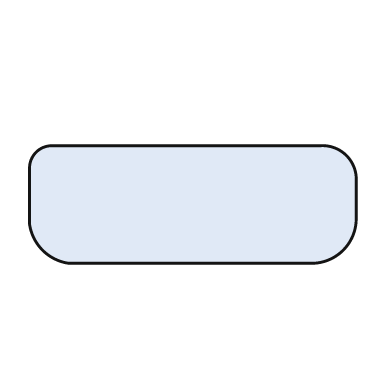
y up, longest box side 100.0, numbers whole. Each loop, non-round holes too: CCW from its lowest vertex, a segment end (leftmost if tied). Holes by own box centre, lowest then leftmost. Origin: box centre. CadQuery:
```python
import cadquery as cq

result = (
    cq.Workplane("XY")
    .moveTo(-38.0, -18.0)
    .lineTo(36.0, -18.0)
    .threePointArc((46.0, -14.0), (50.0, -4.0))
    .lineTo(50.0, 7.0)
    .threePointArc((47.0, 15.0), (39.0, 18.0))
    .lineTo(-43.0, 18.0)
    .threePointArc((-48.0, 16.0), (-50.0, 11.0))
    .lineTo(-50.0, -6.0)
    .threePointArc((-46.0, -14.0), (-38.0, -18.0))
    .close()
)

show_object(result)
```